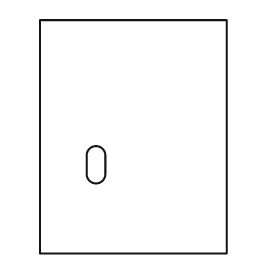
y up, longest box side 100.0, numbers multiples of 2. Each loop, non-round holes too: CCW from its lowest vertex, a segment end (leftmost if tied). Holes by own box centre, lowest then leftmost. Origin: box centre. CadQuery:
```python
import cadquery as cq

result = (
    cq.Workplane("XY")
    .moveTo(-40.0, -50.0)
    .lineTo(40.0, -50.0)
    .lineTo(40.0, 50.0)
    .lineTo(-40.0, 50.0)
    .close()
    .moveTo(-20.0, -16.0)
    .threePointArc((-16.0, -20.0), (-12.0, -16.0))
    .lineTo(-12.0, -8.0)
    .threePointArc((-16.0, -4.0), (-20.0, -8.0))
    .close()
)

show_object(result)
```